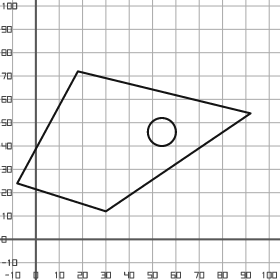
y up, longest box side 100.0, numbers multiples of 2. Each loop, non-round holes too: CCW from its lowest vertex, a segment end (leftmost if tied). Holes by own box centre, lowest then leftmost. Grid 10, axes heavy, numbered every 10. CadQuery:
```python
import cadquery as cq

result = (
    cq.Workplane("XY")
    .moveTo(30.0, 12.0)
    .lineTo(92.0, 54.0)
    .lineTo(18.0, 72.0)
    .lineTo(-8.0, 24.0)
    .close()
    .moveTo(54.0, 46.0)
    .circle(6.0)
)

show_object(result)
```